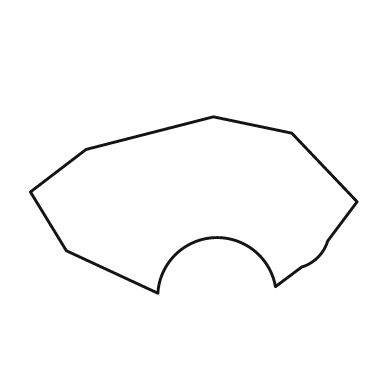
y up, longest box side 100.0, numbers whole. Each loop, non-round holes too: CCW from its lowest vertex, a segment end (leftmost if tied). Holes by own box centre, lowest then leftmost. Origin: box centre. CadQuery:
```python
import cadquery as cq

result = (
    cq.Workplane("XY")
    .moveTo(-11.0, -27.0)
    .threePointArc((6.0, -10.0), (25.0, -25.0))
    .lineTo(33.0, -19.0)
    .threePointArc((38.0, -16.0), (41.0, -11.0))
    .lineTo(50.0, 1.0)
    .lineTo(30.0, 22.0)
    .lineTo(6.0, 27.0)
    .lineTo(-33.0, 17.0)
    .lineTo(-50.0, 4.0)
    .lineTo(-39.0, -14.0)
    .close()
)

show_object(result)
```